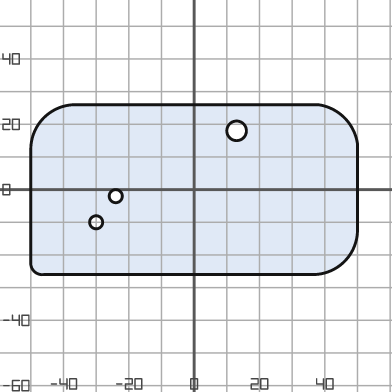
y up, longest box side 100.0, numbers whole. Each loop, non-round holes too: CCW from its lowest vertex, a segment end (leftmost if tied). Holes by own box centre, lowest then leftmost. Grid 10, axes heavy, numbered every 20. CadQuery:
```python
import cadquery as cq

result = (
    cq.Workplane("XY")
    .moveTo(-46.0, -26.0)
    .lineTo(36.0, -26.0)
    .threePointArc((46.0, -22.0), (50.0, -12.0))
    .lineTo(50.0, 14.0)
    .threePointArc((46.0, 22.0), (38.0, 26.0))
    .lineTo(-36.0, 26.0)
    .threePointArc((-46.0, 22.0), (-50.0, 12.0))
    .lineTo(-50.0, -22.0)
    .threePointArc((-49.0, -25.0), (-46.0, -26.0))
    .close()
    .moveTo(-30.0, -10.0)
    .circle(2.0)
    .moveTo(-24.0, -2.0)
    .circle(2.0)
    .moveTo(13.0, 18.0)
    .circle(3.0)
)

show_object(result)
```